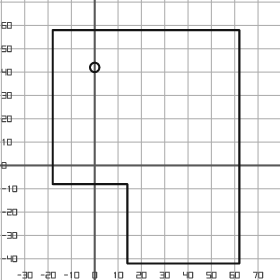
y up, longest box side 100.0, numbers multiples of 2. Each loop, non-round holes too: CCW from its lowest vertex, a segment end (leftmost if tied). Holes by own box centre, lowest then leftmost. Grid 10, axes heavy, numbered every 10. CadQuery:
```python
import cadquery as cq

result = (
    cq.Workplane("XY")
    .moveTo(14.0, -42.0)
    .lineTo(62.0, -42.0)
    .lineTo(62.0, 58.0)
    .lineTo(-18.0, 58.0)
    .lineTo(-18.0, -8.0)
    .lineTo(14.0, -8.0)
    .close()
    .moveTo(0.0, 42.0)
    .circle(2.0)
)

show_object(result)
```